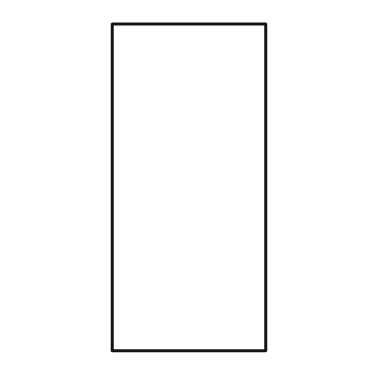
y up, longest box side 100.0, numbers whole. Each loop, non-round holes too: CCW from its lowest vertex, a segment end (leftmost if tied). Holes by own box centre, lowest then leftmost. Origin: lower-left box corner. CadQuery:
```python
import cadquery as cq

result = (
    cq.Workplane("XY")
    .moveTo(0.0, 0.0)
    .lineTo(47.0, 0.0)
    .lineTo(47.0, 100.0)
    .lineTo(0.0, 100.0)
    .close()
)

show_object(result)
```